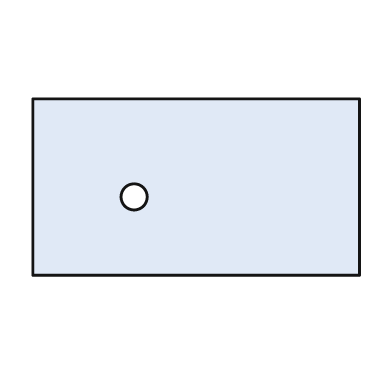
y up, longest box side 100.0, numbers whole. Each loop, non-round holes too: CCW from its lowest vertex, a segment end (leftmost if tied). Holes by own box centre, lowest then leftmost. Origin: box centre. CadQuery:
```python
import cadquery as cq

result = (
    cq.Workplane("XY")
    .moveTo(-50.0, -27.0)
    .lineTo(50.0, -27.0)
    .lineTo(50.0, 27.0)
    .lineTo(-50.0, 27.0)
    .close()
    .moveTo(-19.0, -3.0)
    .circle(4.0)
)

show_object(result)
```